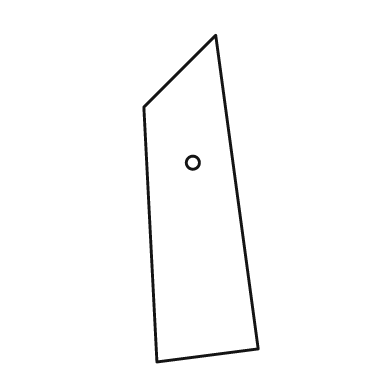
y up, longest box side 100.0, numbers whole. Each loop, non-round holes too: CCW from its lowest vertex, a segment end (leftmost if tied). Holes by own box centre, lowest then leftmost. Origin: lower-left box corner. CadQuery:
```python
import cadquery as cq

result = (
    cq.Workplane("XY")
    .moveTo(4.0, 0.0)
    .lineTo(35.0, 4.0)
    .lineTo(22.0, 100.0)
    .lineTo(0.0, 78.0)
    .close()
    .moveTo(15.0, 61.0)
    .circle(2.0)
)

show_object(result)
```